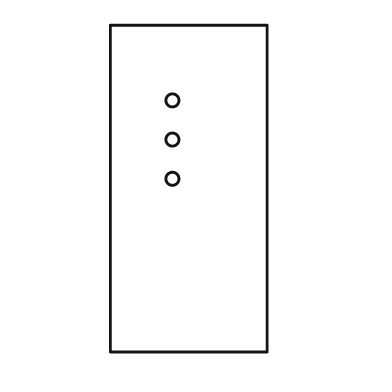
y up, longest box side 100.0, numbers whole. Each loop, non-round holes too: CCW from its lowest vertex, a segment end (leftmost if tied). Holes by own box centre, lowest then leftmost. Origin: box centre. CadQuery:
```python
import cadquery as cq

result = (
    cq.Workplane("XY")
    .moveTo(-24.0, -50.0)
    .lineTo(24.0, -50.0)
    .lineTo(24.0, 50.0)
    .lineTo(-24.0, 50.0)
    .close()
    .moveTo(-5.0, 3.0)
    .circle(2.0)
    .moveTo(-5.0, 15.0)
    .circle(2.0)
    .moveTo(-5.0, 27.0)
    .circle(2.0)
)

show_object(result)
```